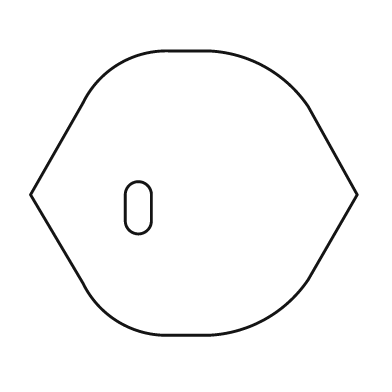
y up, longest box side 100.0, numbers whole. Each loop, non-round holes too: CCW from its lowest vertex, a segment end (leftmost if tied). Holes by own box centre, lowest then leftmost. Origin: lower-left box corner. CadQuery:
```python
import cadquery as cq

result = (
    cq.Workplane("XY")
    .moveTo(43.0, 0.0)
    .lineTo(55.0, 0.0)
    .threePointArc((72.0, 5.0), (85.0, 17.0))
    .lineTo(100.0, 43.0)
    .lineTo(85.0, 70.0)
    .threePointArc((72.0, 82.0), (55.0, 87.0))
    .lineTo(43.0, 87.0)
    .threePointArc((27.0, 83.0), (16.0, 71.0))
    .lineTo(0.0, 43.0)
    .lineTo(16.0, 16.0)
    .threePointArc((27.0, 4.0), (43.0, 0.0))
    .close()
    .moveTo(29.0, 35.0)
    .threePointArc((33.0, 31.0), (37.0, 35.0))
    .lineTo(37.0, 43.0)
    .threePointArc((33.0, 47.0), (29.0, 43.0))
    .close()
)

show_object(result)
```